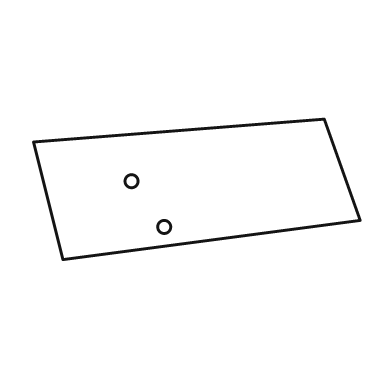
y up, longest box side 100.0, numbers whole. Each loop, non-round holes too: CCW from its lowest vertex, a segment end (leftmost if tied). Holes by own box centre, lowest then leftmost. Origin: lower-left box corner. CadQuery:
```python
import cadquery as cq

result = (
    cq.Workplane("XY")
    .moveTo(9.0, 0.0)
    .lineTo(100.0, 12.0)
    .lineTo(89.0, 43.0)
    .lineTo(0.0, 36.0)
    .close()
    .moveTo(40.0, 10.0)
    .circle(2.0)
    .moveTo(30.0, 24.0)
    .circle(2.0)
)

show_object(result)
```